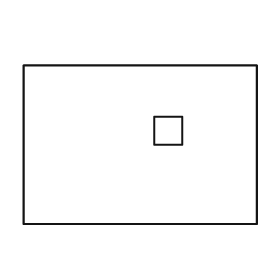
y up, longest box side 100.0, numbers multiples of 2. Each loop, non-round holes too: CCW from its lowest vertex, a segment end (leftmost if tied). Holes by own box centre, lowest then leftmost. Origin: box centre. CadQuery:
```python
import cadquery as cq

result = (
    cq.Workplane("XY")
    .moveTo(-50.0, -34.0)
    .lineTo(50.0, -34.0)
    .lineTo(50.0, 34.0)
    .lineTo(-50.0, 34.0)
    .close()
    .moveTo(6.0, 0.0)
    .lineTo(18.0, 0.0)
    .lineTo(18.0, 12.0)
    .lineTo(6.0, 12.0)
    .close()
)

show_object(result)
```